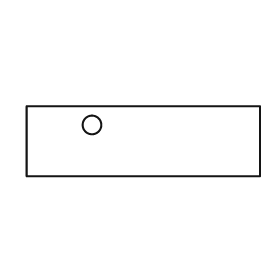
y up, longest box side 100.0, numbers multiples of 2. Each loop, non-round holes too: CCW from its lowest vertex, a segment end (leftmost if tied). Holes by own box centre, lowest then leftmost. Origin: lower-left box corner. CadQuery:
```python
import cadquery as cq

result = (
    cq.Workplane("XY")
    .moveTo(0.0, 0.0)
    .lineTo(100.0, 0.0)
    .lineTo(100.0, 30.0)
    .lineTo(0.0, 30.0)
    .close()
    .moveTo(28.0, 22.0)
    .circle(4.0)
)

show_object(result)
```